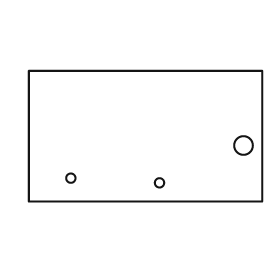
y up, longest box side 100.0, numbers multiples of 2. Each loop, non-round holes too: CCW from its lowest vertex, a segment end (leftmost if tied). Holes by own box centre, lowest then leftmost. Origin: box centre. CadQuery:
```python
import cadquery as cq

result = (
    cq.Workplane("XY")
    .moveTo(-50.0, -28.0)
    .lineTo(50.0, -28.0)
    .lineTo(50.0, 28.0)
    .lineTo(-50.0, 28.0)
    .close()
    .moveTo(6.0, -20.0)
    .circle(2.0)
    .moveTo(-32.0, -18.0)
    .circle(2.0)
    .moveTo(42.0, -4.0)
    .circle(4.0)
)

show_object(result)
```